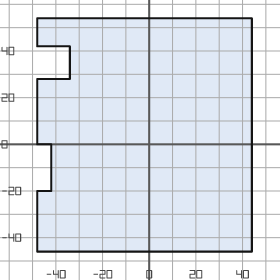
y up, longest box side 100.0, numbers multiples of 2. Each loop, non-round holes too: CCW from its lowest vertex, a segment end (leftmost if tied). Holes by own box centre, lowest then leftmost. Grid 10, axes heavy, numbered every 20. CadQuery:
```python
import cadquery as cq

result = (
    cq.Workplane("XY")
    .moveTo(-48.0, -46.0)
    .lineTo(44.0, -46.0)
    .lineTo(44.0, 54.0)
    .lineTo(-48.0, 54.0)
    .lineTo(-48.0, 42.0)
    .lineTo(-34.0, 42.0)
    .lineTo(-34.0, 28.0)
    .lineTo(-48.0, 28.0)
    .lineTo(-48.0, 0.0)
    .lineTo(-42.0, 0.0)
    .lineTo(-42.0, -20.0)
    .lineTo(-48.0, -20.0)
    .close()
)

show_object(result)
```